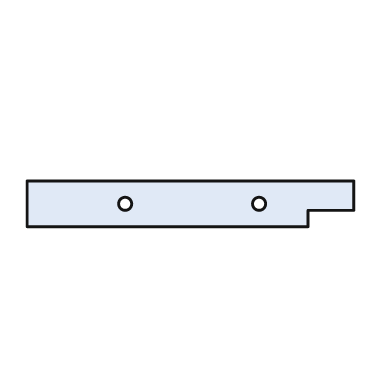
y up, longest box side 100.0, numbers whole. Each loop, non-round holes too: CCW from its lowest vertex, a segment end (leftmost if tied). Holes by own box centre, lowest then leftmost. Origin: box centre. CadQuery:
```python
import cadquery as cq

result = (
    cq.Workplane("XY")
    .moveTo(-50.0, -7.0)
    .lineTo(36.0, -7.0)
    .lineTo(36.0, -2.0)
    .lineTo(50.0, -2.0)
    .lineTo(50.0, 7.0)
    .lineTo(-50.0, 7.0)
    .close()
    .moveTo(-20.0, 0.0)
    .circle(2.0)
    .moveTo(21.0, 0.0)
    .circle(2.0)
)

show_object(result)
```